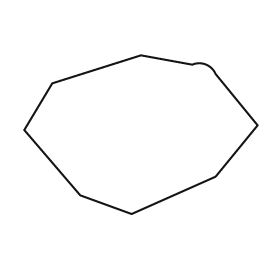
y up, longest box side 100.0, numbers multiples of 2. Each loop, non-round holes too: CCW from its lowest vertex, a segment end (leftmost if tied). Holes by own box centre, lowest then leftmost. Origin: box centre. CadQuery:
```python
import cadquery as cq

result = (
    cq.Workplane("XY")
    .moveTo(-4.0, -34.0)
    .lineTo(32.0, -18.0)
    .lineTo(50.0, 4.0)
    .lineTo(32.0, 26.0)
    .threePointArc((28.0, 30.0), (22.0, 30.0))
    .lineTo(0.0, 34.0)
    .lineTo(-38.0, 22.0)
    .lineTo(-50.0, 2.0)
    .lineTo(-26.0, -26.0)
    .close()
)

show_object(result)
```